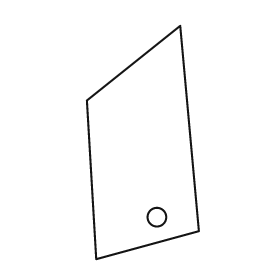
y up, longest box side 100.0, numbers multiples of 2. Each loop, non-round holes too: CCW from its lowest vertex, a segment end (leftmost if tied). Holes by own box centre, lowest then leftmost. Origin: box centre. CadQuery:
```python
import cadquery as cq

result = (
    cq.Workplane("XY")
    .moveTo(-20.0, -50.0)
    .lineTo(24.0, -38.0)
    .lineTo(16.0, 50.0)
    .lineTo(-24.0, 18.0)
    .close()
    .moveTo(6.0, -32.0)
    .circle(4.0)
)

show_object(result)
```